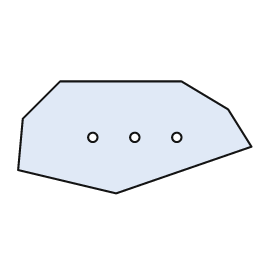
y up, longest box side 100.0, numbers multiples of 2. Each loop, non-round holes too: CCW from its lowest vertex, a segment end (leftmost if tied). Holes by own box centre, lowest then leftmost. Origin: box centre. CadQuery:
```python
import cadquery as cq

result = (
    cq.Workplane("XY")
    .moveTo(-8.0, -24.0)
    .lineTo(50.0, -4.0)
    .lineTo(40.0, 12.0)
    .lineTo(20.0, 24.0)
    .lineTo(-32.0, 24.0)
    .lineTo(-48.0, 8.0)
    .lineTo(-50.0, -14.0)
    .close()
    .moveTo(-18.0, 0.0)
    .circle(2.0)
    .moveTo(0.0, 0.0)
    .circle(2.0)
    .moveTo(18.0, 0.0)
    .circle(2.0)
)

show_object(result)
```